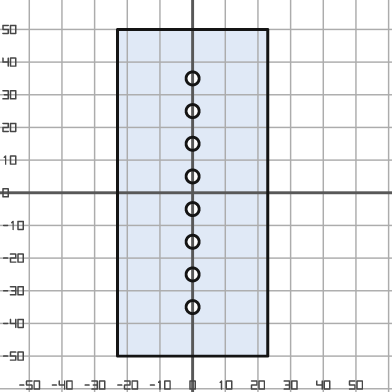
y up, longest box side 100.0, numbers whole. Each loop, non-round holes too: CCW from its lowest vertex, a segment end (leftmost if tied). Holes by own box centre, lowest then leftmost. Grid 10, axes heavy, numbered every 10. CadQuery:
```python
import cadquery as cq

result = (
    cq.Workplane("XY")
    .moveTo(-23.0, -50.0)
    .lineTo(23.0, -50.0)
    .lineTo(23.0, 50.0)
    .lineTo(-23.0, 50.0)
    .close()
    .moveTo(0.0, -35.0)
    .circle(2.0)
    .moveTo(0.0, -25.0)
    .circle(2.0)
    .moveTo(0.0, -15.0)
    .circle(2.0)
    .moveTo(0.0, -5.0)
    .circle(2.0)
    .moveTo(0.0, 5.0)
    .circle(2.0)
    .moveTo(0.0, 15.0)
    .circle(2.0)
    .moveTo(0.0, 25.0)
    .circle(2.0)
    .moveTo(0.0, 35.0)
    .circle(2.0)
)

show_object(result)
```